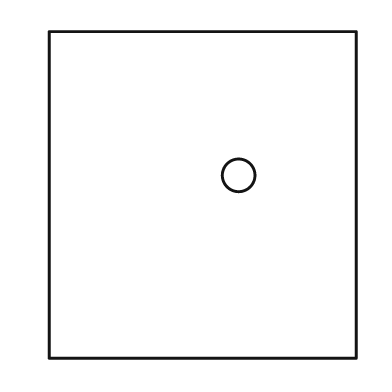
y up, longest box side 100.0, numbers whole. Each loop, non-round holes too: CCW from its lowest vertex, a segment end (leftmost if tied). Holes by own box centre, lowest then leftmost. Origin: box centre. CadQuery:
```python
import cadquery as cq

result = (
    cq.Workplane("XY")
    .moveTo(-47.0, -50.0)
    .lineTo(47.0, -50.0)
    .lineTo(47.0, 50.0)
    .lineTo(-47.0, 50.0)
    .close()
    .moveTo(11.0, 6.0)
    .circle(5.0)
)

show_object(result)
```